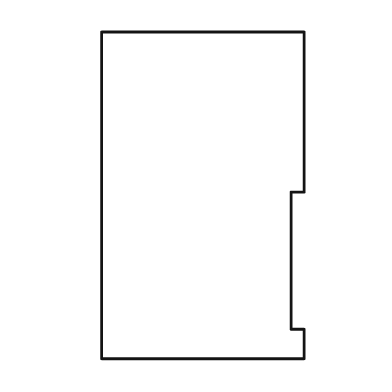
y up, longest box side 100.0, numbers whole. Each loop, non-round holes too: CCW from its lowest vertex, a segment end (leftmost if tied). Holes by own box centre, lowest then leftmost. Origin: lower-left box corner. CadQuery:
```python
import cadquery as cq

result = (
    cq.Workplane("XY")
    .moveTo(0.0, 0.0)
    .lineTo(62.0, 0.0)
    .lineTo(62.0, 9.0)
    .lineTo(58.0, 9.0)
    .lineTo(58.0, 51.0)
    .lineTo(62.0, 51.0)
    .lineTo(62.0, 100.0)
    .lineTo(0.0, 100.0)
    .close()
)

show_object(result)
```